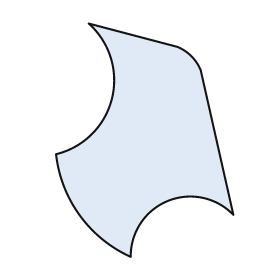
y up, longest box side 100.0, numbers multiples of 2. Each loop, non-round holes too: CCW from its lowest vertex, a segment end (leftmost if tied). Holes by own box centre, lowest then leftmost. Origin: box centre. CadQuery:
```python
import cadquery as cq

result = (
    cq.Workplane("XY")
    .moveTo(-6.0, -50.0)
    .threePointArc((10.0, -26.0), (38.0, -32.0))
    .lineTo(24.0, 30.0)
    .threePointArc((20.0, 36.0), (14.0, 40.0))
    .lineTo(-24.0, 50.0)
    .threePointArc((-14.0, 18.0), (-38.0, -6.0))
    .threePointArc((-28.0, -32.0), (-6.0, -50.0))
    .close()
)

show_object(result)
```